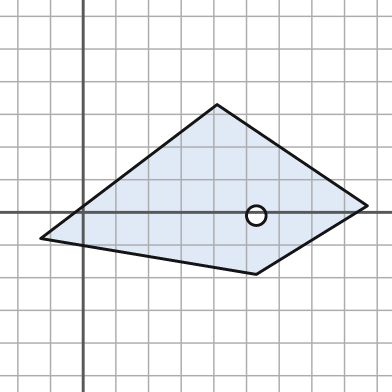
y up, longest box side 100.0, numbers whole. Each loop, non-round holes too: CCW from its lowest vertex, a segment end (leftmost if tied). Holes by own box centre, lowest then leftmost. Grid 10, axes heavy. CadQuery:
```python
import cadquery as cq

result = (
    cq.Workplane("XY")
    .moveTo(53.0, -19.0)
    .lineTo(87.0, 2.0)
    .lineTo(41.0, 33.0)
    .lineTo(-13.0, -8.0)
    .close()
    .moveTo(53.0, -1.0)
    .circle(3.0)
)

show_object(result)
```